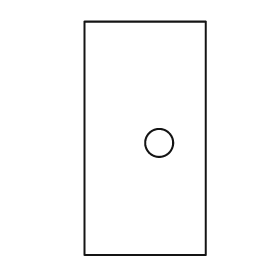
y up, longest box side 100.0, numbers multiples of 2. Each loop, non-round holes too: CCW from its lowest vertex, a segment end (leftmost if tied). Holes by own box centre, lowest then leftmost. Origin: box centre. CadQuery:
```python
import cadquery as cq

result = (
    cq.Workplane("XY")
    .moveTo(-26.0, -50.0)
    .lineTo(26.0, -50.0)
    .lineTo(26.0, 50.0)
    .lineTo(-26.0, 50.0)
    .close()
    .moveTo(6.0, -2.0)
    .circle(6.0)
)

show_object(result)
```